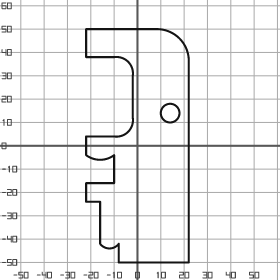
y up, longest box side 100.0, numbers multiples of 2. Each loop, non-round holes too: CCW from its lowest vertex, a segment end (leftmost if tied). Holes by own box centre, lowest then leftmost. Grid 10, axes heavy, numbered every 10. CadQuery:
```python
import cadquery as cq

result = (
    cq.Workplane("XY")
    .moveTo(-8.0, -50.0)
    .lineTo(22.0, -50.0)
    .lineTo(22.0, 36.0)
    .threePointArc((18.0, 46.0), (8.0, 50.0))
    .lineTo(-22.0, 50.0)
    .lineTo(-22.0, 38.0)
    .lineTo(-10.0, 38.0)
    .threePointArc((-4.0, 36.0), (-2.0, 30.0))
    .lineTo(-2.0, 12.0)
    .threePointArc((-4.0, 6.0), (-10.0, 4.0))
    .lineTo(-22.0, 4.0)
    .lineTo(-22.0, -4.0)
    .threePointArc((-16.0, -6.0), (-10.0, -4.0))
    .lineTo(-10.0, -16.0)
    .lineTo(-22.0, -16.0)
    .lineTo(-22.0, -24.0)
    .lineTo(-16.0, -24.0)
    .lineTo(-16.0, -42.0)
    .threePointArc((-12.0, -44.0), (-8.0, -42.0))
    .close()
    .moveTo(14.0, 14.0)
    .circle(4.0)
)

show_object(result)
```